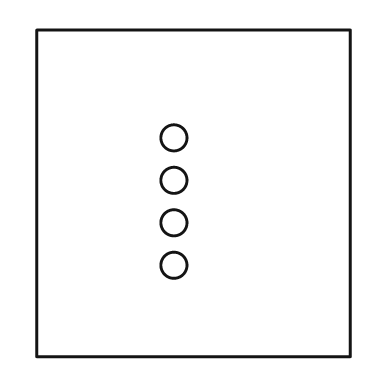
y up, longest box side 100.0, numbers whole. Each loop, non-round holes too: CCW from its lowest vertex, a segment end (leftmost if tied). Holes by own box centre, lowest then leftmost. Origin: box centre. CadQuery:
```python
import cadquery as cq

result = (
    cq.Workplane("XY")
    .moveTo(-48.0, -50.0)
    .lineTo(48.0, -50.0)
    .lineTo(48.0, 50.0)
    .lineTo(-48.0, 50.0)
    .close()
    .moveTo(-6.0, -22.0)
    .circle(4.0)
    .moveTo(-6.0, -9.0)
    .circle(4.0)
    .moveTo(-6.0, 4.0)
    .circle(4.0)
    .moveTo(-6.0, 17.0)
    .circle(4.0)
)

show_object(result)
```